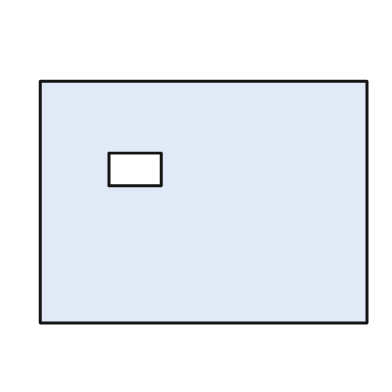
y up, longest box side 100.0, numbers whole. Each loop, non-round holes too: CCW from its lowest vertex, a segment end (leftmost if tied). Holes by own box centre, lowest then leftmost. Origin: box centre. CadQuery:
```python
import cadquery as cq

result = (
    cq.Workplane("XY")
    .moveTo(-50.0, -37.0)
    .lineTo(50.0, -37.0)
    .lineTo(50.0, 37.0)
    .lineTo(-50.0, 37.0)
    .close()
    .moveTo(-29.0, 5.0)
    .lineTo(-13.0, 5.0)
    .lineTo(-13.0, 15.0)
    .lineTo(-29.0, 15.0)
    .close()
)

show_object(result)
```